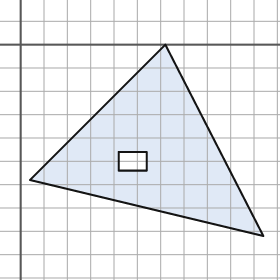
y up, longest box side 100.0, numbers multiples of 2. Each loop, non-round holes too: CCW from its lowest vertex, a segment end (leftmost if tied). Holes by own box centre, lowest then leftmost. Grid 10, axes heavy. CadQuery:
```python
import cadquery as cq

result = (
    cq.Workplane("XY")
    .moveTo(104.0, -82.0)
    .lineTo(62.0, 0.0)
    .lineTo(4.0, -58.0)
    .close()
    .moveTo(42.0, -54.0)
    .lineTo(54.0, -54.0)
    .lineTo(54.0, -46.0)
    .lineTo(42.0, -46.0)
    .close()
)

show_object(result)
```